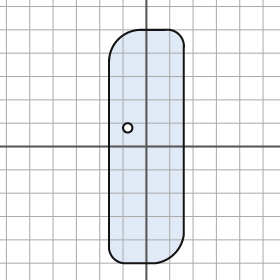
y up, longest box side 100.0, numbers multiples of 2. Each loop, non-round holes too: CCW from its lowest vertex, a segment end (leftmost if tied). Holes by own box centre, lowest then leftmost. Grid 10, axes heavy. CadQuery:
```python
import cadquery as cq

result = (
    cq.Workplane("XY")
    .moveTo(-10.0, -50.0)
    .lineTo(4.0, -50.0)
    .threePointArc((12.0, -46.0), (16.0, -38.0))
    .lineTo(16.0, 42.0)
    .threePointArc((14.0, 48.0), (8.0, 50.0))
    .lineTo(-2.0, 50.0)
    .threePointArc((-12.0, 46.0), (-16.0, 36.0))
    .lineTo(-16.0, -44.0)
    .threePointArc((-14.0, -48.0), (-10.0, -50.0))
    .close()
    .moveTo(-8.0, 8.0)
    .circle(2.0)
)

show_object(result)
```